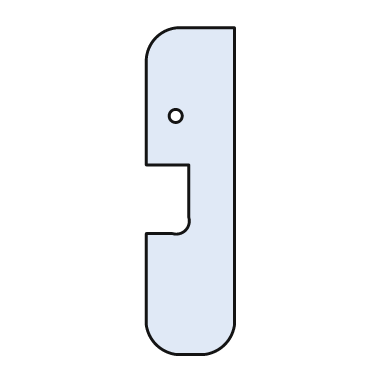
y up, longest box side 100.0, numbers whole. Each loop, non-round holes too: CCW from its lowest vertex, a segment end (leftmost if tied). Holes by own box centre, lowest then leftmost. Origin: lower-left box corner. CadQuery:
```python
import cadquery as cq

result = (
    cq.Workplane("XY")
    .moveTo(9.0, 0.0)
    .lineTo(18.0, 0.0)
    .threePointArc((24.0, 3.0), (27.0, 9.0))
    .lineTo(27.0, 100.0)
    .lineTo(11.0, 100.0)
    .threePointArc((3.0, 97.0), (0.0, 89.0))
    .lineTo(0.0, 58.0)
    .lineTo(13.0, 58.0)
    .lineTo(13.0, 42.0)
    .threePointArc((12.0, 38.0), (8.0, 37.0))
    .lineTo(0.0, 37.0)
    .lineTo(0.0, 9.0)
    .threePointArc((3.0, 3.0), (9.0, 0.0))
    .close()
    .moveTo(9.0, 73.0)
    .circle(2.0)
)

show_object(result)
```